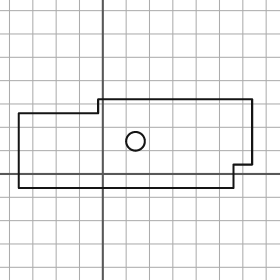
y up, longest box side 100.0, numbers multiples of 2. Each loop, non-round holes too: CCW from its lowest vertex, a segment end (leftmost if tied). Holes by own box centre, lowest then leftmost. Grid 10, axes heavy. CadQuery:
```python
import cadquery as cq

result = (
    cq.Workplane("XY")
    .moveTo(-36.0, -6.0)
    .lineTo(56.0, -6.0)
    .lineTo(56.0, 4.0)
    .lineTo(64.0, 4.0)
    .lineTo(64.0, 32.0)
    .lineTo(-2.0, 32.0)
    .lineTo(-2.0, 26.0)
    .lineTo(-36.0, 26.0)
    .close()
    .moveTo(14.0, 14.0)
    .circle(4.0)
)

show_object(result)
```